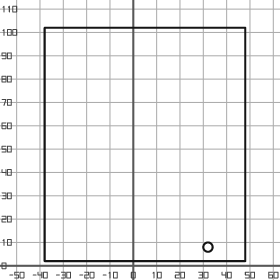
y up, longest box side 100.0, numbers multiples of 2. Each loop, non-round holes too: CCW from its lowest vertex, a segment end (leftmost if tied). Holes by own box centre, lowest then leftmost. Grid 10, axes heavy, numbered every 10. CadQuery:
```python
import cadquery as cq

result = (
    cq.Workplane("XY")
    .moveTo(-38.0, 2.0)
    .lineTo(48.0, 2.0)
    .lineTo(48.0, 102.0)
    .lineTo(-38.0, 102.0)
    .close()
    .moveTo(32.0, 8.0)
    .circle(2.0)
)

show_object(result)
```